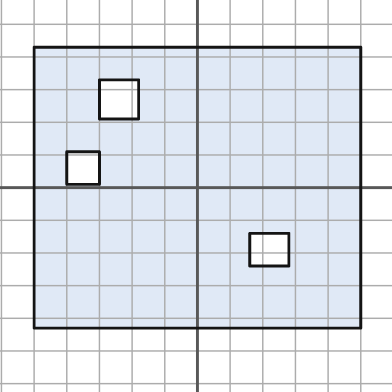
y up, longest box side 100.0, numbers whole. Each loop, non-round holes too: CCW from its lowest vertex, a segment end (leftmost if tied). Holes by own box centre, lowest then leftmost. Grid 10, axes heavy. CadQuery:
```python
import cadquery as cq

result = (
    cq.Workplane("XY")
    .moveTo(-50.0, -43.0)
    .lineTo(50.0, -43.0)
    .lineTo(50.0, 43.0)
    .lineTo(-50.0, 43.0)
    .close()
    .moveTo(16.0, -24.0)
    .lineTo(28.0, -24.0)
    .lineTo(28.0, -14.0)
    .lineTo(16.0, -14.0)
    .close()
    .moveTo(-40.0, 1.0)
    .lineTo(-30.0, 1.0)
    .lineTo(-30.0, 11.0)
    .lineTo(-40.0, 11.0)
    .close()
    .moveTo(-30.0, 21.0)
    .lineTo(-18.0, 21.0)
    .lineTo(-18.0, 33.0)
    .lineTo(-30.0, 33.0)
    .close()
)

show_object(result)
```